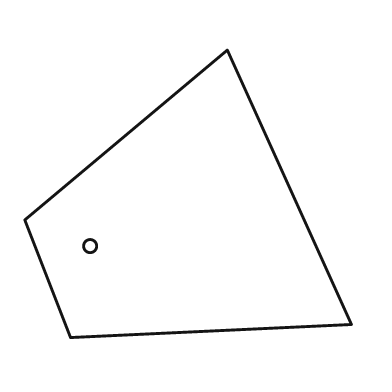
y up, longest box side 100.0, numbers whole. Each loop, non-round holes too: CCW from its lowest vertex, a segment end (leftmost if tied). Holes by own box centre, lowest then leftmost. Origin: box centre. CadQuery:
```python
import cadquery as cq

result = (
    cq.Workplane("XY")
    .moveTo(-36.0, -44.0)
    .lineTo(50.0, -40.0)
    .lineTo(12.0, 44.0)
    .lineTo(-50.0, -8.0)
    .close()
    .moveTo(-30.0, -16.0)
    .circle(2.0)
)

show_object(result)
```